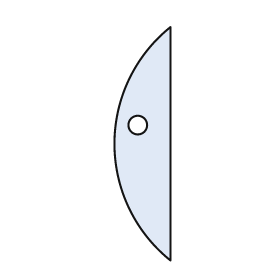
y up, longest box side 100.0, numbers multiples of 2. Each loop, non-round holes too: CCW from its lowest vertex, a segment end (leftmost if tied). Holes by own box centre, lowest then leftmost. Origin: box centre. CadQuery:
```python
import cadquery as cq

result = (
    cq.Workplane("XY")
    .moveTo(12.0, -50.0)
    .lineTo(12.0, 50.0)
    .threePointArc((-12.0, 0.0), (12.0, -50.0))
    .close()
    .moveTo(-2.0, 8.0)
    .circle(4.0)
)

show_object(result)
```